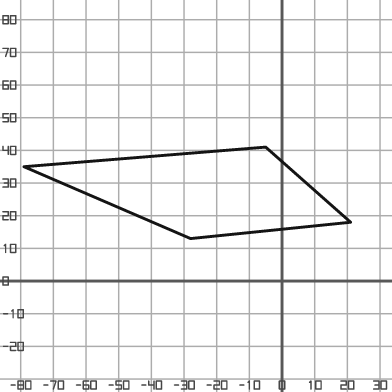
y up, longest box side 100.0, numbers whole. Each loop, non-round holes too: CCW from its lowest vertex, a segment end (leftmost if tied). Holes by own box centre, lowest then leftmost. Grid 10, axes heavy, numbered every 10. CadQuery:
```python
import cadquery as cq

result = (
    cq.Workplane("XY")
    .moveTo(-28.0, 13.0)
    .lineTo(21.0, 18.0)
    .lineTo(-5.0, 41.0)
    .lineTo(-79.0, 35.0)
    .close()
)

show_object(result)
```